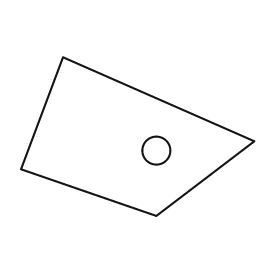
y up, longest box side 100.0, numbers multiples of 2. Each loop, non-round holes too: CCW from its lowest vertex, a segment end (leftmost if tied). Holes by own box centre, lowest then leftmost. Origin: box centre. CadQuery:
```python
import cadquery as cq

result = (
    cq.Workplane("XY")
    .moveTo(8.0, -34.0)
    .lineTo(50.0, -2.0)
    .lineTo(-32.0, 34.0)
    .lineTo(-50.0, -14.0)
    .close()
    .moveTo(8.0, -6.0)
    .circle(6.0)
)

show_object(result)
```